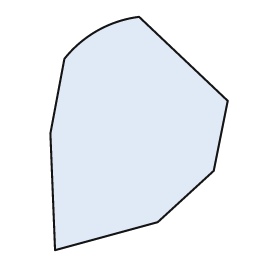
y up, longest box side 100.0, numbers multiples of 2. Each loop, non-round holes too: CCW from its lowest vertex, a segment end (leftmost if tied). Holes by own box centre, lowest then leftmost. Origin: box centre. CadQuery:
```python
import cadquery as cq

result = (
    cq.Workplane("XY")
    .moveTo(-36.0, -50.0)
    .lineTo(8.0, -38.0)
    .lineTo(32.0, -16.0)
    .lineTo(38.0, 14.0)
    .lineTo(0.0, 50.0)
    .threePointArc((-18.0, 44.0), (-32.0, 32.0))
    .lineTo(-38.0, 0.0)
    .close()
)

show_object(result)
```